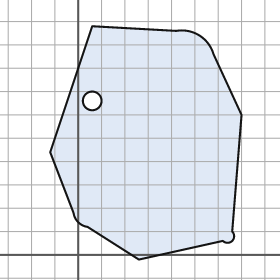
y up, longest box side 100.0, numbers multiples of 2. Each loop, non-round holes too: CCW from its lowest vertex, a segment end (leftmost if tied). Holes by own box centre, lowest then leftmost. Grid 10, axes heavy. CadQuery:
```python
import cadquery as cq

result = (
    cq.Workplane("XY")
    .moveTo(26.0, -2.0)
    .lineTo(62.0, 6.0)
    .threePointArc((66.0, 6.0), (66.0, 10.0))
    .lineTo(70.0, 60.0)
    .lineTo(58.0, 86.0)
    .threePointArc((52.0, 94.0), (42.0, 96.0))
    .lineTo(6.0, 98.0)
    .lineTo(-12.0, 44.0)
    .lineTo(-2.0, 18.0)
    .threePointArc((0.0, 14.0), (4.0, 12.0))
    .close()
    .moveTo(6.0, 66.0)
    .circle(4.0)
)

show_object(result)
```